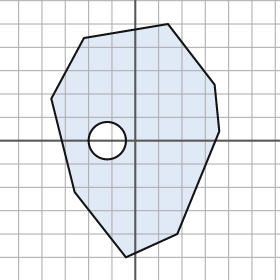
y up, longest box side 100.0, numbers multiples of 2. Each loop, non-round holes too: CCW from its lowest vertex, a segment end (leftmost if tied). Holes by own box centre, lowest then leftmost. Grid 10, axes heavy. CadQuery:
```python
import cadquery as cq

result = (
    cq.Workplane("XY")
    .moveTo(-4.0, -50.0)
    .lineTo(18.0, -40.0)
    .lineTo(36.0, 4.0)
    .lineTo(34.0, 24.0)
    .lineTo(14.0, 50.0)
    .lineTo(-22.0, 44.0)
    .lineTo(-36.0, 18.0)
    .lineTo(-26.0, -22.0)
    .close()
    .moveTo(-12.0, 0.0)
    .circle(8.0)
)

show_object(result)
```